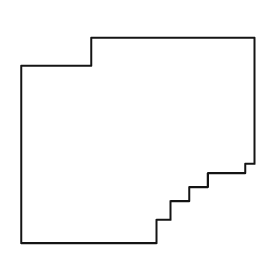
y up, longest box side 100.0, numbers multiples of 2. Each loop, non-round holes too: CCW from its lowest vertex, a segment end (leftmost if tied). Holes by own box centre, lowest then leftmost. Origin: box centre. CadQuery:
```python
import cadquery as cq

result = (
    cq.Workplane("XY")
    .moveTo(-50.0, -44.0)
    .lineTo(8.0, -44.0)
    .lineTo(8.0, -34.0)
    .lineTo(14.0, -34.0)
    .lineTo(14.0, -26.0)
    .lineTo(22.0, -26.0)
    .lineTo(22.0, -20.0)
    .lineTo(30.0, -20.0)
    .lineTo(30.0, -14.0)
    .lineTo(46.0, -14.0)
    .lineTo(46.0, -10.0)
    .lineTo(50.0, -10.0)
    .lineTo(50.0, 44.0)
    .lineTo(-20.0, 44.0)
    .lineTo(-20.0, 32.0)
    .lineTo(-50.0, 32.0)
    .close()
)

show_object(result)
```